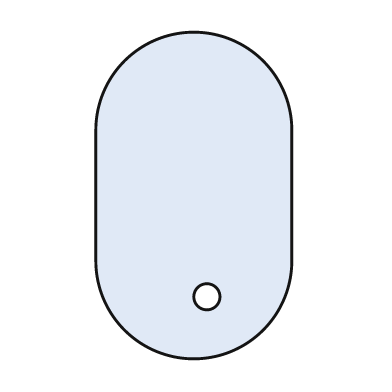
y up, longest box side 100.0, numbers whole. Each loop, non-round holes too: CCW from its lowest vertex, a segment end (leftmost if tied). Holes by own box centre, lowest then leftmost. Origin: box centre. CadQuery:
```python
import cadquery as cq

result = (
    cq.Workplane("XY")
    .moveTo(-30.0, -20.0)
    .threePointArc((0.0, -50.0), (30.0, -20.0))
    .lineTo(30.0, 20.0)
    .threePointArc((0.0, 50.0), (-30.0, 20.0))
    .close()
    .moveTo(4.0, -31.0)
    .circle(4.0)
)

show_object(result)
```